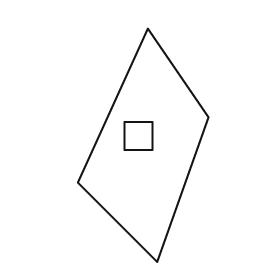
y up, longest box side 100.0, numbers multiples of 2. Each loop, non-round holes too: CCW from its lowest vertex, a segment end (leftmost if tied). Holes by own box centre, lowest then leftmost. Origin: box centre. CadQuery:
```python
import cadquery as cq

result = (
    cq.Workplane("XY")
    .moveTo(6.0, -50.0)
    .lineTo(28.0, 12.0)
    .lineTo(2.0, 50.0)
    .lineTo(-28.0, -16.0)
    .close()
    .moveTo(-8.0, -2.0)
    .lineTo(4.0, -2.0)
    .lineTo(4.0, 10.0)
    .lineTo(-8.0, 10.0)
    .close()
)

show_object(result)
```